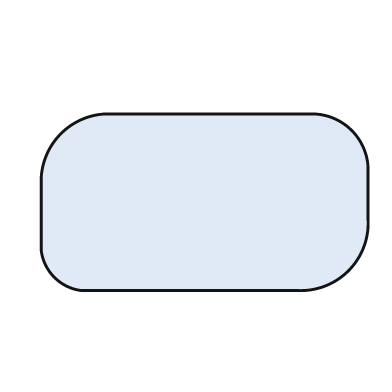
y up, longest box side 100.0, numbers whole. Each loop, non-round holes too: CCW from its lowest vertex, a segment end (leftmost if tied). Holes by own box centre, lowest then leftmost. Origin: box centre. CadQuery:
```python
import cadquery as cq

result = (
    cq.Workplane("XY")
    .moveTo(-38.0, -27.0)
    .lineTo(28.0, -27.0)
    .threePointArc((44.0, -21.0), (50.0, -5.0))
    .lineTo(50.0, 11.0)
    .threePointArc((45.0, 22.0), (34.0, 27.0))
    .lineTo(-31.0, 27.0)
    .threePointArc((-44.0, 21.0), (-50.0, 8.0))
    .lineTo(-50.0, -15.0)
    .threePointArc((-46.0, -23.0), (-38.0, -27.0))
    .close()
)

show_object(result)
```